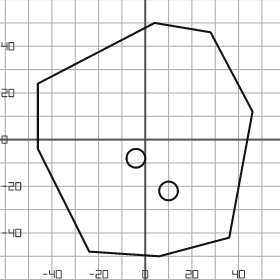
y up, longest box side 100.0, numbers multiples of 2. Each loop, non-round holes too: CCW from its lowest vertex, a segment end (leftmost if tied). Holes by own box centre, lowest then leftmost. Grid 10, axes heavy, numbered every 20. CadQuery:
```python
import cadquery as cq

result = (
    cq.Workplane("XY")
    .moveTo(6.0, -50.0)
    .lineTo(36.0, -42.0)
    .lineTo(46.0, 12.0)
    .lineTo(28.0, 46.0)
    .lineTo(4.0, 50.0)
    .lineTo(-46.0, 24.0)
    .lineTo(-46.0, -4.0)
    .lineTo(-24.0, -48.0)
    .close()
    .moveTo(10.0, -22.0)
    .circle(4.0)
    .moveTo(-4.0, -8.0)
    .circle(4.0)
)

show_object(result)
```